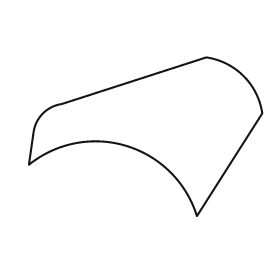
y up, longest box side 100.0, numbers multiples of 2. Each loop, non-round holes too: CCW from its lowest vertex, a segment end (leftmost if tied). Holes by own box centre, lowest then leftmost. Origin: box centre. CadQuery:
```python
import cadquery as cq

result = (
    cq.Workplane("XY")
    .moveTo(22.0, -34.0)
    .lineTo(50.0, 10.0)
    .threePointArc((42.0, 26.0), (26.0, 34.0))
    .lineTo(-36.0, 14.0)
    .threePointArc((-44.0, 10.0), (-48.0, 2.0))
    .lineTo(-50.0, -12.0)
    .threePointArc((-8.0, -4.0), (22.0, -34.0))
    .close()
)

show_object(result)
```